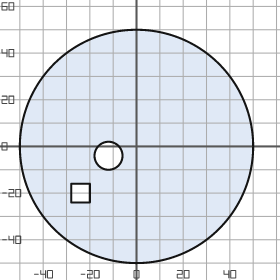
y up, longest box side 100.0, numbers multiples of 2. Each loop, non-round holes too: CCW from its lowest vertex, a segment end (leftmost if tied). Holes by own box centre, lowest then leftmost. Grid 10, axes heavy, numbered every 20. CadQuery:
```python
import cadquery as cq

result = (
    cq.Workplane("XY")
    .moveTo(0.0, 0.0)
    .circle(50.0)
    .moveTo(-28.0, -24.0)
    .lineTo(-20.0, -24.0)
    .lineTo(-20.0, -16.0)
    .lineTo(-28.0, -16.0)
    .close()
    .moveTo(-12.0, -4.0)
    .circle(6.0)
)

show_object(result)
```